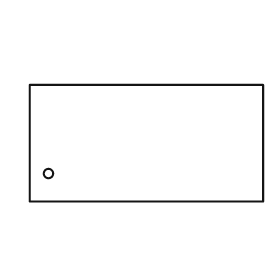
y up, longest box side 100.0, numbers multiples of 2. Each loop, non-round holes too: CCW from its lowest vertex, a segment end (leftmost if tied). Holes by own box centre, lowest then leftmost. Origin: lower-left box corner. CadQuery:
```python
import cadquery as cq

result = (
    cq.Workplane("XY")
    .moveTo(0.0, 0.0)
    .lineTo(100.0, 0.0)
    .lineTo(100.0, 50.0)
    .lineTo(0.0, 50.0)
    .close()
    .moveTo(8.0, 12.0)
    .circle(2.0)
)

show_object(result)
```